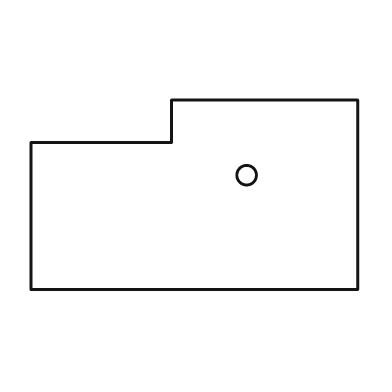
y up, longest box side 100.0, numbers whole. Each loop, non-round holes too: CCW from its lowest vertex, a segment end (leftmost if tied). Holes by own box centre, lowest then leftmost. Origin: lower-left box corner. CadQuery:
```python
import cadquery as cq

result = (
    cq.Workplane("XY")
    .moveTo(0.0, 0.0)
    .lineTo(100.0, 0.0)
    .lineTo(100.0, 58.0)
    .lineTo(43.0, 58.0)
    .lineTo(43.0, 45.0)
    .lineTo(0.0, 45.0)
    .close()
    .moveTo(66.0, 35.0)
    .circle(3.0)
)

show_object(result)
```